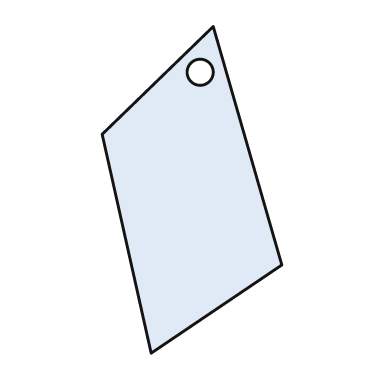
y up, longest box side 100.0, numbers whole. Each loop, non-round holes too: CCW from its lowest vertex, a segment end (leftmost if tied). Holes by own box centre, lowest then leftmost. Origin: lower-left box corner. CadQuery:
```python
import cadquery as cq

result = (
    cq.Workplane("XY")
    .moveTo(15.0, 0.0)
    .lineTo(55.0, 27.0)
    .lineTo(34.0, 100.0)
    .lineTo(0.0, 67.0)
    .close()
    .moveTo(30.0, 86.0)
    .circle(4.0)
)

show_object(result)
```